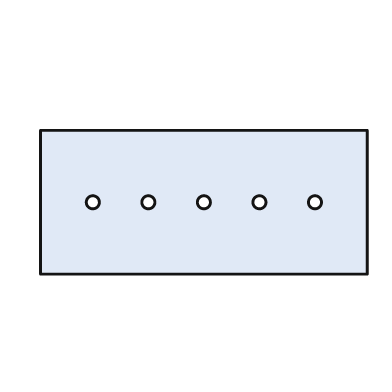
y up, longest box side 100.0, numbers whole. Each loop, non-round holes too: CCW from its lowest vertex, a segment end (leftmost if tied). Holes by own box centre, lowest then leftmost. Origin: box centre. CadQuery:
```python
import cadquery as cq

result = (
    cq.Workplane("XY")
    .moveTo(-50.0, -22.0)
    .lineTo(50.0, -22.0)
    .lineTo(50.0, 22.0)
    .lineTo(-50.0, 22.0)
    .close()
    .moveTo(-34.0, 0.0)
    .circle(2.0)
    .moveTo(-17.0, 0.0)
    .circle(2.0)
    .moveTo(0.0, 0.0)
    .circle(2.0)
    .moveTo(17.0, 0.0)
    .circle(2.0)
    .moveTo(34.0, 0.0)
    .circle(2.0)
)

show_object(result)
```